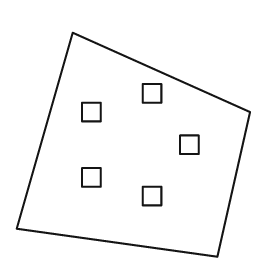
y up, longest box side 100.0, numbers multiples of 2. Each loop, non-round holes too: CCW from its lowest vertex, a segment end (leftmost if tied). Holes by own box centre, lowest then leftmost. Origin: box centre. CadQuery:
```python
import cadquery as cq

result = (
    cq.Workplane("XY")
    .moveTo(36.0, -48.0)
    .lineTo(50.0, 14.0)
    .lineTo(-26.0, 48.0)
    .lineTo(-50.0, -36.0)
    .close()
    .moveTo(4.0, -26.0)
    .lineTo(12.0, -26.0)
    .lineTo(12.0, -18.0)
    .lineTo(4.0, -18.0)
    .close()
    .moveTo(-22.0, -18.0)
    .lineTo(-14.0, -18.0)
    .lineTo(-14.0, -10.0)
    .lineTo(-22.0, -10.0)
    .close()
    .moveTo(20.0, -4.0)
    .lineTo(28.0, -4.0)
    .lineTo(28.0, 4.0)
    .lineTo(20.0, 4.0)
    .close()
    .moveTo(-22.0, 10.0)
    .lineTo(-14.0, 10.0)
    .lineTo(-14.0, 18.0)
    .lineTo(-22.0, 18.0)
    .close()
    .moveTo(4.0, 18.0)
    .lineTo(12.0, 18.0)
    .lineTo(12.0, 26.0)
    .lineTo(4.0, 26.0)
    .close()
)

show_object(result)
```